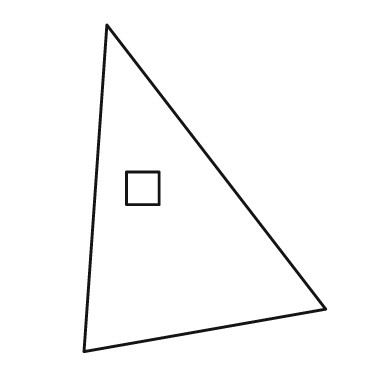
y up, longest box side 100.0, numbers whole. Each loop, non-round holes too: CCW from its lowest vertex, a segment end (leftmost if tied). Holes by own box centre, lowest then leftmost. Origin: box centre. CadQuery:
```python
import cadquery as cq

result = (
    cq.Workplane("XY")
    .moveTo(-37.0, -50.0)
    .lineTo(37.0, -37.0)
    .lineTo(-30.0, 50.0)
    .close()
    .moveTo(-24.0, -5.0)
    .lineTo(-14.0, -5.0)
    .lineTo(-14.0, 5.0)
    .lineTo(-24.0, 5.0)
    .close()
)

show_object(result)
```